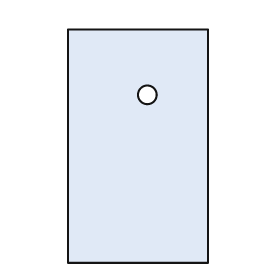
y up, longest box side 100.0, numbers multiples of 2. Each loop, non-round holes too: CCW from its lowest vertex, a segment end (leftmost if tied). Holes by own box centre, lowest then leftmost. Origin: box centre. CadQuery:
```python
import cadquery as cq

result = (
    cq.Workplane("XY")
    .moveTo(-30.0, -50.0)
    .lineTo(30.0, -50.0)
    .lineTo(30.0, 50.0)
    .lineTo(-30.0, 50.0)
    .close()
    .moveTo(4.0, 22.0)
    .circle(4.0)
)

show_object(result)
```